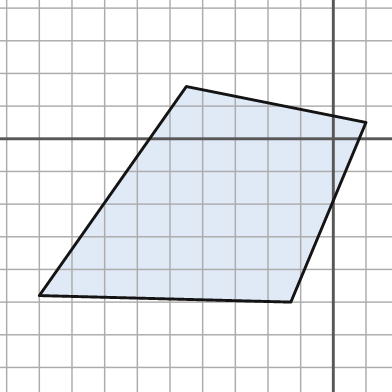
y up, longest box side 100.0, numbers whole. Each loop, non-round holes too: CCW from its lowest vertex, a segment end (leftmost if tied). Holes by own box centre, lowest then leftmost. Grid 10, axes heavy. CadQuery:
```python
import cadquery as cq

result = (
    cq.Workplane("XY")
    .moveTo(-13.0, -50.0)
    .lineTo(10.0, 5.0)
    .lineTo(-45.0, 16.0)
    .lineTo(-90.0, -48.0)
    .close()
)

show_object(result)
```